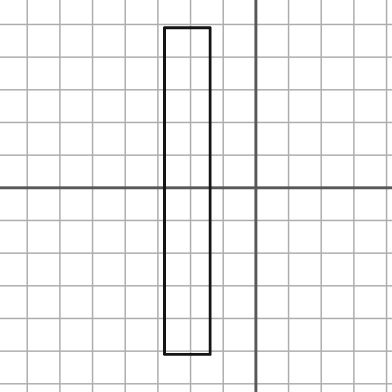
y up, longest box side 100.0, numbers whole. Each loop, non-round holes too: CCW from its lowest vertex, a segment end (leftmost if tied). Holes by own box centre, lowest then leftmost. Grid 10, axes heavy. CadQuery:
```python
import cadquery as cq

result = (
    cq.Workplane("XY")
    .moveTo(-28.0, -51.0)
    .lineTo(-14.0, -51.0)
    .lineTo(-14.0, 49.0)
    .lineTo(-28.0, 49.0)
    .close()
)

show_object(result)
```